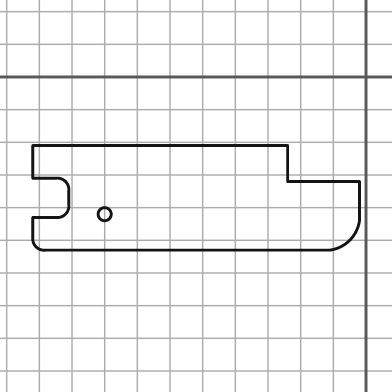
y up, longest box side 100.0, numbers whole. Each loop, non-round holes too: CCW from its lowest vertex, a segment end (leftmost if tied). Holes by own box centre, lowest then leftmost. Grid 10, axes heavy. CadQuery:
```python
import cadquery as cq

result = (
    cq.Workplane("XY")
    .moveTo(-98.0, -53.0)
    .lineTo(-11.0, -53.0)
    .threePointArc((-5.0, -50.0), (-2.0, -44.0))
    .lineTo(-2.0, -32.0)
    .lineTo(-24.0, -32.0)
    .lineTo(-24.0, -21.0)
    .lineTo(-102.0, -21.0)
    .lineTo(-102.0, -31.0)
    .lineTo(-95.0, -31.0)
    .threePointArc((-92.0, -32.0), (-91.0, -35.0))
    .lineTo(-91.0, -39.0)
    .threePointArc((-92.0, -42.0), (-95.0, -43.0))
    .lineTo(-102.0, -43.0)
    .lineTo(-102.0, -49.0)
    .threePointArc((-101.0, -52.0), (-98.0, -53.0))
    .close()
    .moveTo(-80.0, -42.0)
    .circle(2.0)
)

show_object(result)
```